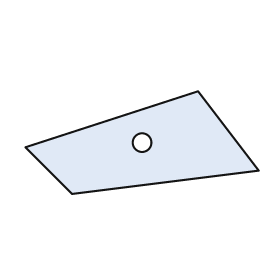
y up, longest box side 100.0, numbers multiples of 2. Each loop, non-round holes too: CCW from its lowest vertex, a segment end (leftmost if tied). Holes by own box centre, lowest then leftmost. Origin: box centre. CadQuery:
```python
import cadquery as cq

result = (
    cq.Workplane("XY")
    .moveTo(-30.0, -22.0)
    .lineTo(50.0, -12.0)
    .lineTo(24.0, 22.0)
    .lineTo(-50.0, -2.0)
    .close()
    .moveTo(0.0, 0.0)
    .circle(4.0)
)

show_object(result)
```